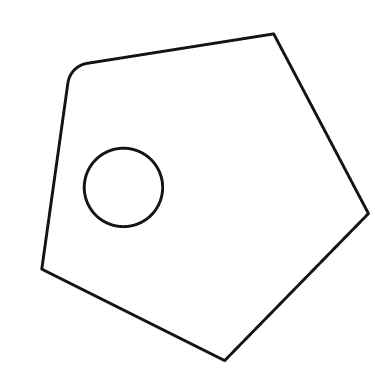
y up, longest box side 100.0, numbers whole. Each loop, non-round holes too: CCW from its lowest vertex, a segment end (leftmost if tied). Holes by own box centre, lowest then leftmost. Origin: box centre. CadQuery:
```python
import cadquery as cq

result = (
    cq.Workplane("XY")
    .moveTo(6.0, -50.0)
    .lineTo(50.0, -5.0)
    .lineTo(21.0, 50.0)
    .lineTo(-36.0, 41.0)
    .threePointArc((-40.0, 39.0), (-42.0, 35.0))
    .lineTo(-50.0, -22.0)
    .close()
    .moveTo(-25.0, 3.0)
    .circle(12.0)
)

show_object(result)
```